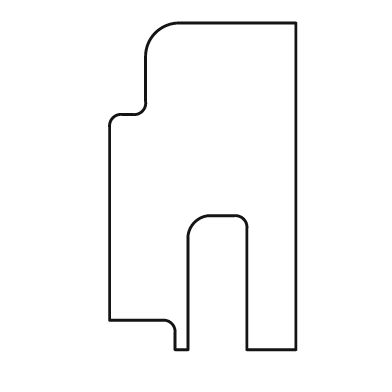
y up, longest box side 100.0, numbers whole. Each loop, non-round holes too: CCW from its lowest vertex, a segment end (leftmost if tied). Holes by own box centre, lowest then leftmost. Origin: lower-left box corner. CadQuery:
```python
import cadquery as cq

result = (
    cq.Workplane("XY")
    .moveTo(20.0, 0.0)
    .lineTo(24.0, 0.0)
    .lineTo(24.0, 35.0)
    .threePointArc((26.0, 39.0), (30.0, 41.0))
    .lineTo(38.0, 41.0)
    .threePointArc((41.0, 40.0), (42.0, 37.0))
    .lineTo(42.0, 0.0)
    .lineTo(57.0, 0.0)
    .lineTo(57.0, 100.0)
    .lineTo(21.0, 100.0)
    .threePointArc((14.0, 97.0), (11.0, 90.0))
    .lineTo(11.0, 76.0)
    .threePointArc((10.0, 73.0), (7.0, 72.0))
    .lineTo(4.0, 72.0)
    .threePointArc((1.0, 71.0), (0.0, 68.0))
    .lineTo(0.0, 9.0)
    .lineTo(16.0, 9.0)
    .threePointArc((19.0, 8.0), (20.0, 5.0))
    .close()
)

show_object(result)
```